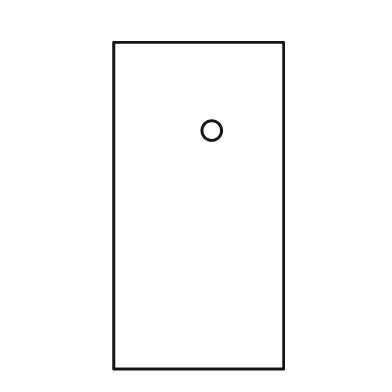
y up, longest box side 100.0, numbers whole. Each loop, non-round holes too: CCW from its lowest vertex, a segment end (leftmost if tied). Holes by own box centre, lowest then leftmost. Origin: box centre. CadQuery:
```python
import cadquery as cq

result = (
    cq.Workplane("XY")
    .moveTo(-26.0, -50.0)
    .lineTo(26.0, -50.0)
    .lineTo(26.0, 50.0)
    .lineTo(-26.0, 50.0)
    .close()
    .moveTo(4.0, 23.0)
    .circle(3.0)
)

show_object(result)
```